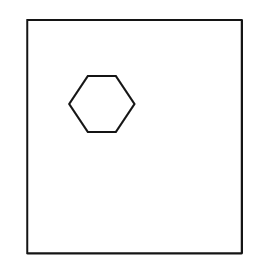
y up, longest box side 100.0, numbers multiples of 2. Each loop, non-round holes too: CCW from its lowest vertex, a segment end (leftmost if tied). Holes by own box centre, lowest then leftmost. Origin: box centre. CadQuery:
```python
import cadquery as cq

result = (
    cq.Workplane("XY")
    .moveTo(-46.0, -50.0)
    .lineTo(46.0, -50.0)
    .lineTo(46.0, 50.0)
    .lineTo(-46.0, 50.0)
    .close()
    .moveTo(-20.0, 2.0)
    .lineTo(-8.0, 2.0)
    .lineTo(0.0, 14.0)
    .lineTo(-8.0, 26.0)
    .lineTo(-20.0, 26.0)
    .lineTo(-28.0, 14.0)
    .close()
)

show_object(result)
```